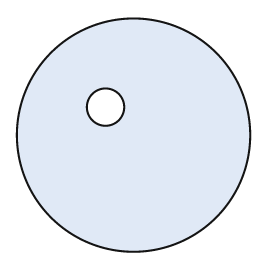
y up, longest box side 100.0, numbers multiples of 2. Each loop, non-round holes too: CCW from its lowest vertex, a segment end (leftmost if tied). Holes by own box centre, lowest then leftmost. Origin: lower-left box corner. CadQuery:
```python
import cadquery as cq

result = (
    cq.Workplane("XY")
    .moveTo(50.0, 50.0)
    .circle(50.0)
    .moveTo(38.0, 62.0)
    .circle(8.0)
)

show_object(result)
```